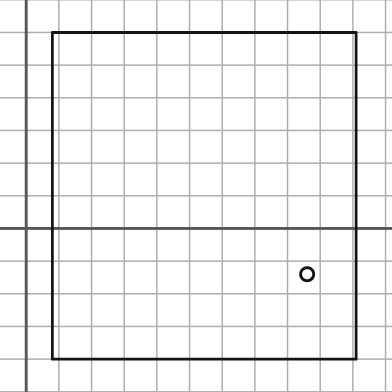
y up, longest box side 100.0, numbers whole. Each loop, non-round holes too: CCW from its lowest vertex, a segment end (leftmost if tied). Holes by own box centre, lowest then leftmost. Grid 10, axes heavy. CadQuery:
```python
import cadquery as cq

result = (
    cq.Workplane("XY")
    .moveTo(8.0, -40.0)
    .lineTo(101.0, -40.0)
    .lineTo(101.0, 60.0)
    .lineTo(8.0, 60.0)
    .close()
    .moveTo(86.0, -14.0)
    .circle(2.0)
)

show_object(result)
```